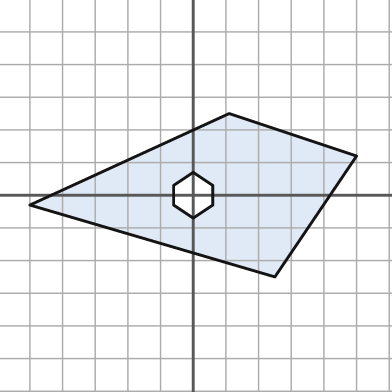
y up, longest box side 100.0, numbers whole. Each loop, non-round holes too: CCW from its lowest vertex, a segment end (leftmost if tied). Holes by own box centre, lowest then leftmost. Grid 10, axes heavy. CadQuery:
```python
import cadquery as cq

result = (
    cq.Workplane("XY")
    .moveTo(25.0, -25.0)
    .lineTo(50.0, 12.0)
    .lineTo(11.0, 25.0)
    .lineTo(-50.0, -3.0)
    .close()
    .moveTo(0.0, -7.0)
    .lineTo(6.0, -3.0)
    .lineTo(6.0, 3.0)
    .lineTo(0.0, 7.0)
    .lineTo(-6.0, 3.0)
    .lineTo(-6.0, -3.0)
    .close()
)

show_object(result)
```